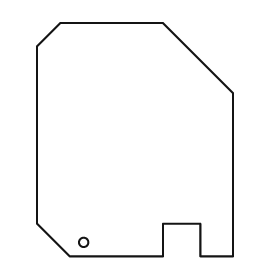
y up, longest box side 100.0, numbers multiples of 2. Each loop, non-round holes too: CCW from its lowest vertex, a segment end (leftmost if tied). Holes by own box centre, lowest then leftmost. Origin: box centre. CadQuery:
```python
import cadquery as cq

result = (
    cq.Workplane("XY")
    .moveTo(-28.0, -50.0)
    .lineTo(12.0, -50.0)
    .lineTo(12.0, -36.0)
    .lineTo(28.0, -36.0)
    .lineTo(28.0, -50.0)
    .lineTo(42.0, -50.0)
    .lineTo(42.0, 20.0)
    .lineTo(12.0, 50.0)
    .lineTo(-32.0, 50.0)
    .lineTo(-42.0, 40.0)
    .lineTo(-42.0, -36.0)
    .close()
    .moveTo(-22.0, -44.0)
    .circle(2.0)
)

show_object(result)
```